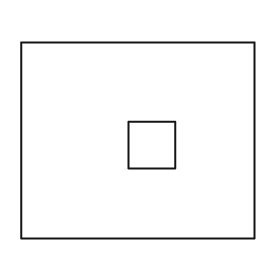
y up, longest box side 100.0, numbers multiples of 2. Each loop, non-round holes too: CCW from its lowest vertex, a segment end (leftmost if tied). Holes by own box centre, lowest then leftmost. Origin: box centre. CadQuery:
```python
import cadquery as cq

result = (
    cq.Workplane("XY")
    .moveTo(-50.0, -42.0)
    .lineTo(50.0, -42.0)
    .lineTo(50.0, 42.0)
    .lineTo(-50.0, 42.0)
    .close()
    .moveTo(-4.0, -12.0)
    .lineTo(16.0, -12.0)
    .lineTo(16.0, 8.0)
    .lineTo(-4.0, 8.0)
    .close()
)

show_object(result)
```